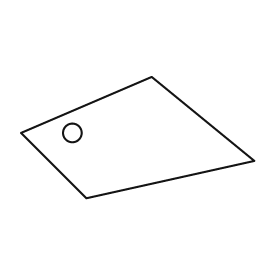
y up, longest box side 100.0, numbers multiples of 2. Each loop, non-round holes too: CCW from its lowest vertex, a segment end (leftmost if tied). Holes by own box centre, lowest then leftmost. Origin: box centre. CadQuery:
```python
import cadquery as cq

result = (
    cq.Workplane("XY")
    .moveTo(-22.0, -26.0)
    .lineTo(50.0, -10.0)
    .lineTo(6.0, 26.0)
    .lineTo(-50.0, 2.0)
    .close()
    .moveTo(-28.0, 2.0)
    .circle(4.0)
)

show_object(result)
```